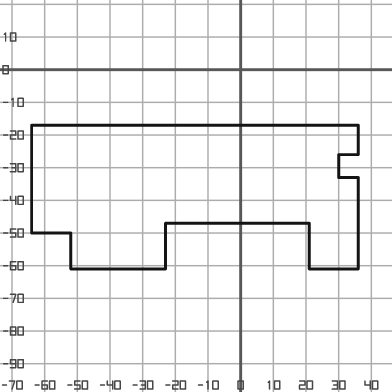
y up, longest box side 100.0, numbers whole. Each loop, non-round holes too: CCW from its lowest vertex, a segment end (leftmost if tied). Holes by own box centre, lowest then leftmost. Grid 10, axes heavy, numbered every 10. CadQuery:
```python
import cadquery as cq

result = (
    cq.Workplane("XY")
    .moveTo(-52.0, -61.0)
    .lineTo(-23.0, -61.0)
    .lineTo(-23.0, -47.0)
    .lineTo(21.0, -47.0)
    .lineTo(21.0, -61.0)
    .lineTo(36.0, -61.0)
    .lineTo(36.0, -33.0)
    .lineTo(30.0, -33.0)
    .lineTo(30.0, -26.0)
    .lineTo(36.0, -26.0)
    .lineTo(36.0, -17.0)
    .lineTo(-64.0, -17.0)
    .lineTo(-64.0, -50.0)
    .lineTo(-52.0, -50.0)
    .close()
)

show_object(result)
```